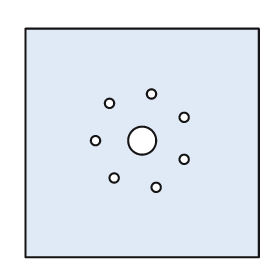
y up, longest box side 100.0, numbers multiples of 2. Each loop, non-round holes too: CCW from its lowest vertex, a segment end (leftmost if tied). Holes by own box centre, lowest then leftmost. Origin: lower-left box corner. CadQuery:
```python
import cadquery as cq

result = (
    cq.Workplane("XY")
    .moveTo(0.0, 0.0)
    .lineTo(100.0, 0.0)
    .lineTo(100.0, 98.0)
    .lineTo(0.0, 98.0)
    .close()
    .moveTo(56.0, 30.0)
    .circle(2.0)
    .moveTo(38.0, 34.0)
    .circle(2.0)
    .moveTo(68.0, 42.0)
    .circle(2.0)
    .moveTo(30.0, 50.0)
    .circle(2.0)
    .moveTo(50.0, 50.0)
    .circle(6.0)
    .moveTo(68.0, 60.0)
    .circle(2.0)
    .moveTo(36.0, 66.0)
    .circle(2.0)
    .moveTo(54.0, 70.0)
    .circle(2.0)
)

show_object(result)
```